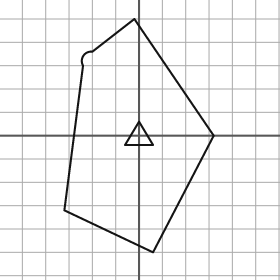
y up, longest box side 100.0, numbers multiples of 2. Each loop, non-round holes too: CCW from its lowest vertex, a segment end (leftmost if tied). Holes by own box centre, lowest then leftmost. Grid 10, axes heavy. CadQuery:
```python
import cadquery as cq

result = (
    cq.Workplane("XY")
    .moveTo(6.0, -50.0)
    .lineTo(32.0, 0.0)
    .lineTo(-2.0, 50.0)
    .lineTo(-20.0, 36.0)
    .threePointArc((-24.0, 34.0), (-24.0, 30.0))
    .lineTo(-32.0, -32.0)
    .close()
    .moveTo(-6.0, -4.0)
    .lineTo(6.0, -4.0)
    .lineTo(0.0, 6.0)
    .close()
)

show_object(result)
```